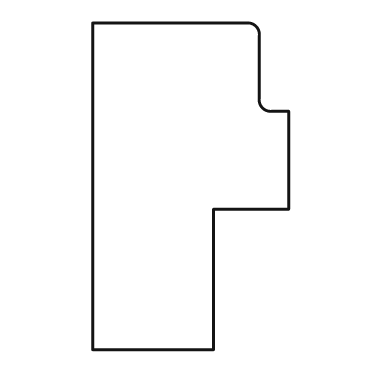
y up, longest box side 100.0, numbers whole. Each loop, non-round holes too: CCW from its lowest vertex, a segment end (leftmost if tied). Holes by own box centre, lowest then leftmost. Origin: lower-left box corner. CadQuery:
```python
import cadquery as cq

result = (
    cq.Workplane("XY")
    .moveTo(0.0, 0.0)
    .lineTo(37.0, 0.0)
    .lineTo(37.0, 43.0)
    .lineTo(60.0, 43.0)
    .lineTo(60.0, 73.0)
    .lineTo(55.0, 73.0)
    .threePointArc((52.0, 74.0), (51.0, 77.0))
    .lineTo(51.0, 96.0)
    .threePointArc((50.0, 99.0), (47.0, 100.0))
    .lineTo(0.0, 100.0)
    .close()
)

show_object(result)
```